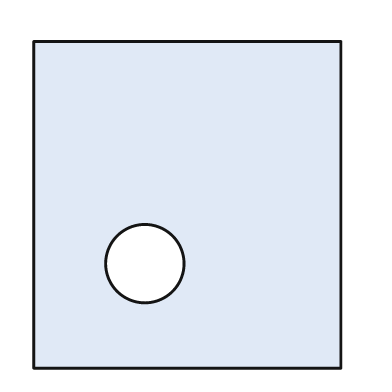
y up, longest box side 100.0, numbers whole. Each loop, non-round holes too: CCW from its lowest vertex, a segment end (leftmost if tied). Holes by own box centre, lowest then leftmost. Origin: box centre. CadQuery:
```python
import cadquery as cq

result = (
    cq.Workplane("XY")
    .moveTo(-47.0, -50.0)
    .lineTo(47.0, -50.0)
    .lineTo(47.0, 50.0)
    .lineTo(-47.0, 50.0)
    .close()
    .moveTo(-13.0, -18.0)
    .circle(12.0)
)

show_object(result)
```